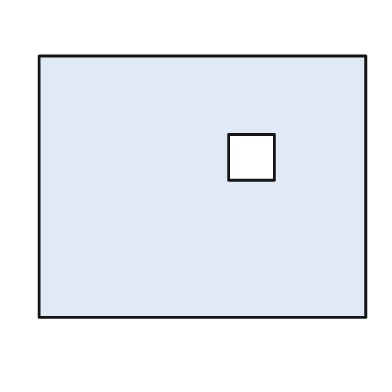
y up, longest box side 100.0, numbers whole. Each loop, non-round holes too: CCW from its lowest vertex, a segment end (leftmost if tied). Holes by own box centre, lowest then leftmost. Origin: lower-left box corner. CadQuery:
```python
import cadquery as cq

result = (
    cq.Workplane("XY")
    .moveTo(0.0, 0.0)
    .lineTo(100.0, 0.0)
    .lineTo(100.0, 80.0)
    .lineTo(0.0, 80.0)
    .close()
    .moveTo(58.0, 42.0)
    .lineTo(72.0, 42.0)
    .lineTo(72.0, 56.0)
    .lineTo(58.0, 56.0)
    .close()
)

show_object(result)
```